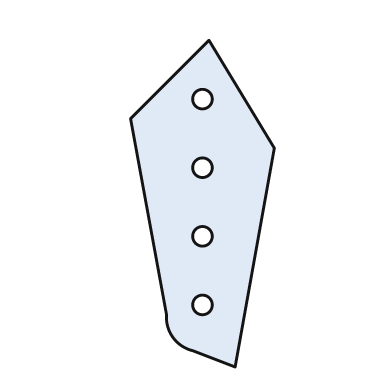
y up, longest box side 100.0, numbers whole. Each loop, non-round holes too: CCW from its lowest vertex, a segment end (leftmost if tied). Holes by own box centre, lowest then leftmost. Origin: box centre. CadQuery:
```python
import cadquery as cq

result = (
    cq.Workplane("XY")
    .moveTo(10.0, -50.0)
    .lineTo(22.0, 17.0)
    .lineTo(2.0, 50.0)
    .lineTo(-22.0, 26.0)
    .lineTo(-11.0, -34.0)
    .threePointArc((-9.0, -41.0), (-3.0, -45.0))
    .close()
    .moveTo(0.0, -31.0)
    .circle(3.0)
    .moveTo(0.0, -10.0)
    .circle(3.0)
    .moveTo(0.0, 11.0)
    .circle(3.0)
    .moveTo(0.0, 32.0)
    .circle(3.0)
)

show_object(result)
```